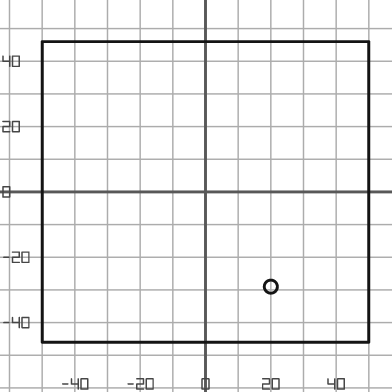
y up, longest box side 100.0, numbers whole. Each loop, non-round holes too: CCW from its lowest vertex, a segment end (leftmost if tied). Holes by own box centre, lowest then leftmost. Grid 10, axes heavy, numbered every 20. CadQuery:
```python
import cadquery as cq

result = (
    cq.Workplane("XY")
    .moveTo(-50.0, -46.0)
    .lineTo(50.0, -46.0)
    .lineTo(50.0, 46.0)
    .lineTo(-50.0, 46.0)
    .close()
    .moveTo(20.0, -29.0)
    .circle(2.0)
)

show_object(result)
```